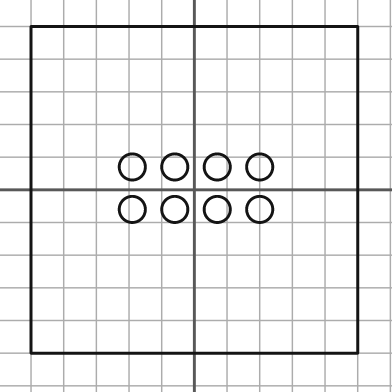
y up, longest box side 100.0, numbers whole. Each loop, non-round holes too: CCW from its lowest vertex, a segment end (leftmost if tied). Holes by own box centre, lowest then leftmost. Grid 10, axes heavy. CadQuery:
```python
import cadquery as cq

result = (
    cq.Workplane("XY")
    .moveTo(-50.0, -50.0)
    .lineTo(50.0, -50.0)
    .lineTo(50.0, 50.0)
    .lineTo(-50.0, 50.0)
    .close()
    .moveTo(-19.0, -6.0)
    .circle(4.0)
    .moveTo(-6.0, -6.0)
    .circle(4.0)
    .moveTo(7.0, -6.0)
    .circle(4.0)
    .moveTo(20.0, -6.0)
    .circle(4.0)
    .moveTo(-19.0, 7.0)
    .circle(4.0)
    .moveTo(-6.0, 7.0)
    .circle(4.0)
    .moveTo(7.0, 7.0)
    .circle(4.0)
    .moveTo(20.0, 7.0)
    .circle(4.0)
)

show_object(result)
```